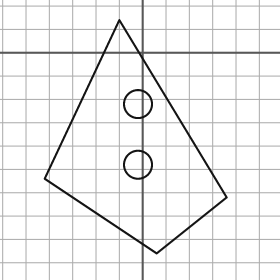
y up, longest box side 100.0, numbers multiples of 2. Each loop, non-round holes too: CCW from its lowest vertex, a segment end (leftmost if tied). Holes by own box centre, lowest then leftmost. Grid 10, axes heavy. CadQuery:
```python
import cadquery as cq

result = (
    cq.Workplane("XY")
    .moveTo(6.0, -86.0)
    .lineTo(36.0, -62.0)
    .lineTo(-10.0, 14.0)
    .lineTo(-42.0, -54.0)
    .close()
    .moveTo(-2.0, -48.0)
    .circle(6.0)
    .moveTo(-2.0, -22.0)
    .circle(6.0)
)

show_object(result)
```